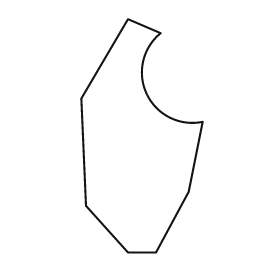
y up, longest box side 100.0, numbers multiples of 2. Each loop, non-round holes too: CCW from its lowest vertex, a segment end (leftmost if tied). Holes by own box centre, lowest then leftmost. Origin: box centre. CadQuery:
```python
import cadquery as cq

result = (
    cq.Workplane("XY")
    .moveTo(-6.0, -50.0)
    .lineTo(6.0, -50.0)
    .lineTo(20.0, -24.0)
    .lineTo(26.0, 6.0)
    .threePointArc((2.0, 18.0), (8.0, 44.0))
    .lineTo(-6.0, 50.0)
    .lineTo(-26.0, 16.0)
    .lineTo(-24.0, -30.0)
    .close()
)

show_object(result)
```